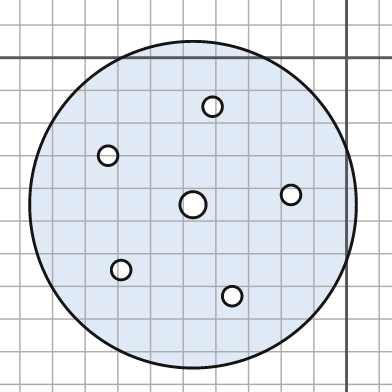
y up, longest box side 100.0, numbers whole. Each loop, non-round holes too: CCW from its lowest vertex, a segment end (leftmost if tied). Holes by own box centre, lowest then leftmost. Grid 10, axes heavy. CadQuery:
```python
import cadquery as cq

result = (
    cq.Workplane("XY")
    .moveTo(-47.0, -45.0)
    .circle(50.0)
    .moveTo(-35.0, -73.0)
    .circle(3.0)
    .moveTo(-69.0, -65.0)
    .circle(3.0)
    .moveTo(-47.0, -45.0)
    .circle(4.0)
    .moveTo(-17.0, -42.0)
    .circle(3.0)
    .moveTo(-73.0, -30.0)
    .circle(3.0)
    .moveTo(-41.0, -15.0)
    .circle(3.0)
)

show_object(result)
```